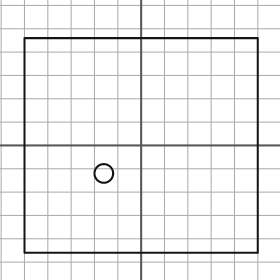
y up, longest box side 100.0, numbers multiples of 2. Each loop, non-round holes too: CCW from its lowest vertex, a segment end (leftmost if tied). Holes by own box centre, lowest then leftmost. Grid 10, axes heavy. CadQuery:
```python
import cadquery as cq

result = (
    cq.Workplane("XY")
    .moveTo(-50.0, -46.0)
    .lineTo(50.0, -46.0)
    .lineTo(50.0, 46.0)
    .lineTo(-50.0, 46.0)
    .close()
    .moveTo(-16.0, -12.0)
    .circle(4.0)
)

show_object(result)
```